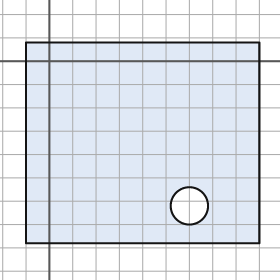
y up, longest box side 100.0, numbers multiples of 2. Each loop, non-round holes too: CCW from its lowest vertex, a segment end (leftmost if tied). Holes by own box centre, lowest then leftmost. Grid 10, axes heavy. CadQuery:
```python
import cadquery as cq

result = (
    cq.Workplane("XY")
    .moveTo(-10.0, -78.0)
    .lineTo(90.0, -78.0)
    .lineTo(90.0, 8.0)
    .lineTo(-10.0, 8.0)
    .close()
    .moveTo(60.0, -62.0)
    .circle(8.0)
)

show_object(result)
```